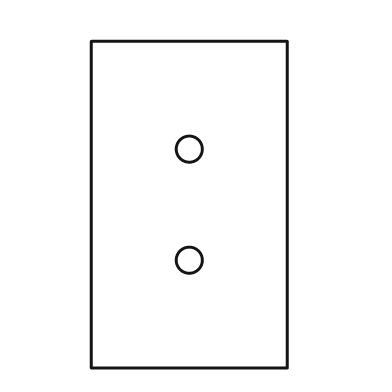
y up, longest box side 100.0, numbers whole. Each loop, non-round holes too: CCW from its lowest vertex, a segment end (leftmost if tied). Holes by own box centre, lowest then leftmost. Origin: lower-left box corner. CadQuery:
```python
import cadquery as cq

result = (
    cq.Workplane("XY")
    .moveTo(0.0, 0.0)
    .lineTo(60.0, 0.0)
    .lineTo(60.0, 100.0)
    .lineTo(0.0, 100.0)
    .close()
    .moveTo(30.0, 33.0)
    .circle(4.0)
    .moveTo(30.0, 67.0)
    .circle(4.0)
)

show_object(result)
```